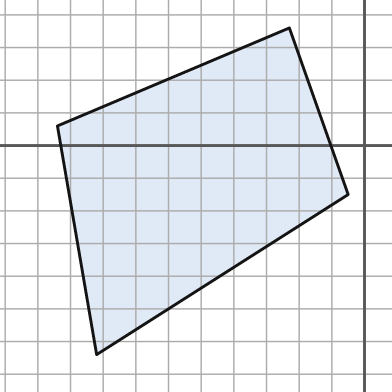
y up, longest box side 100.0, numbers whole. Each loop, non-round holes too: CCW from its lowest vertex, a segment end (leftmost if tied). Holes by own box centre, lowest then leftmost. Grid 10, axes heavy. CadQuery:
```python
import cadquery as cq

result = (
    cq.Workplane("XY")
    .moveTo(-82.0, -64.0)
    .lineTo(-5.0, -15.0)
    .lineTo(-23.0, 36.0)
    .lineTo(-94.0, 6.0)
    .close()
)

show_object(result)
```